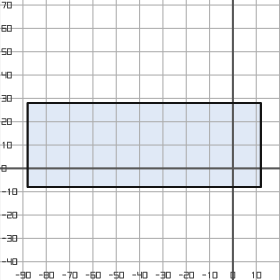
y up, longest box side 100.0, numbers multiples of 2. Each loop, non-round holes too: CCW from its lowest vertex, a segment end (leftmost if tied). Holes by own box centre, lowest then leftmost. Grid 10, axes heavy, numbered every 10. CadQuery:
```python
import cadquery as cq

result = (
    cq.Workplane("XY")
    .moveTo(-88.0, -8.0)
    .lineTo(12.0, -8.0)
    .lineTo(12.0, 28.0)
    .lineTo(-88.0, 28.0)
    .close()
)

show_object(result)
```